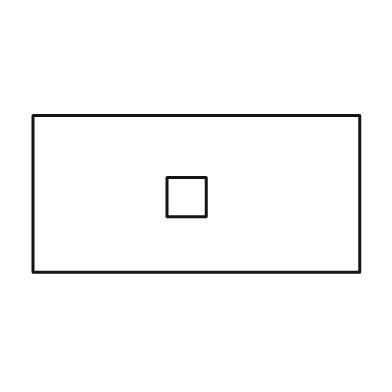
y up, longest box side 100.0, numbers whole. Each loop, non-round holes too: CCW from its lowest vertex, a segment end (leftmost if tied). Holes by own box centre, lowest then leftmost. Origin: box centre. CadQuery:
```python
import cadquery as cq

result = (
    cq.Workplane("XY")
    .moveTo(-50.0, -24.0)
    .lineTo(50.0, -24.0)
    .lineTo(50.0, 24.0)
    .lineTo(-50.0, 24.0)
    .close()
    .moveTo(-9.0, -7.0)
    .lineTo(3.0, -7.0)
    .lineTo(3.0, 5.0)
    .lineTo(-9.0, 5.0)
    .close()
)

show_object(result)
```